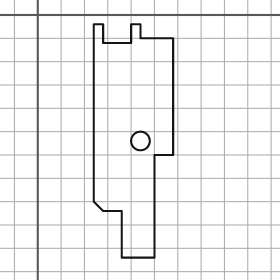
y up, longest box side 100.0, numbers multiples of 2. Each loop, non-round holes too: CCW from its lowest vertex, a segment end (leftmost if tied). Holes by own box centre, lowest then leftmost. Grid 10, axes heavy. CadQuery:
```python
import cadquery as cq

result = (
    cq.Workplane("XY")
    .moveTo(36.0, -104.0)
    .lineTo(50.0, -104.0)
    .lineTo(50.0, -60.0)
    .lineTo(58.0, -60.0)
    .lineTo(58.0, -10.0)
    .lineTo(44.0, -10.0)
    .lineTo(44.0, -4.0)
    .lineTo(40.0, -4.0)
    .lineTo(40.0, -12.0)
    .lineTo(28.0, -12.0)
    .lineTo(28.0, -4.0)
    .lineTo(24.0, -4.0)
    .lineTo(24.0, -80.0)
    .lineTo(28.0, -84.0)
    .lineTo(36.0, -84.0)
    .close()
    .moveTo(44.0, -54.0)
    .circle(4.0)
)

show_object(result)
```